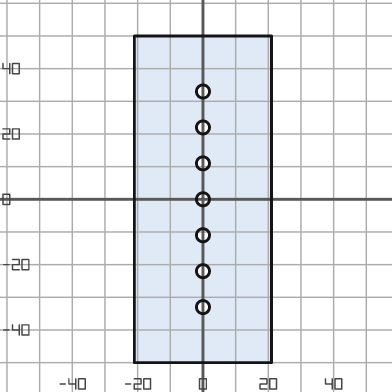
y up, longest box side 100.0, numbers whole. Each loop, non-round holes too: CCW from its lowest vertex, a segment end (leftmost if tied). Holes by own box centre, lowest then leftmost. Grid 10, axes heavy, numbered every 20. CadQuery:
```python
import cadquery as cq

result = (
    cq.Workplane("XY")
    .moveTo(-21.0, -50.0)
    .lineTo(21.0, -50.0)
    .lineTo(21.0, 50.0)
    .lineTo(-21.0, 50.0)
    .close()
    .moveTo(0.0, -33.0)
    .circle(2.0)
    .moveTo(0.0, -22.0)
    .circle(2.0)
    .moveTo(0.0, -11.0)
    .circle(2.0)
    .moveTo(0.0, 0.0)
    .circle(2.0)
    .moveTo(0.0, 11.0)
    .circle(2.0)
    .moveTo(0.0, 22.0)
    .circle(2.0)
    .moveTo(0.0, 33.0)
    .circle(2.0)
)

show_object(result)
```